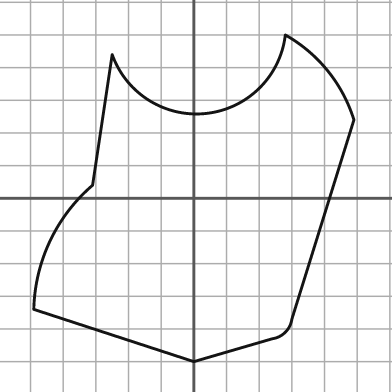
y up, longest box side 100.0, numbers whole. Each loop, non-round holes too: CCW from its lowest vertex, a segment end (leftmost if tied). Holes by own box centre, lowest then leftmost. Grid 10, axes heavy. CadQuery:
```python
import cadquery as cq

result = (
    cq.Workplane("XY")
    .moveTo(0.0, -50.0)
    .lineTo(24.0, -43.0)
    .threePointArc((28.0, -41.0), (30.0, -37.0))
    .lineTo(49.0, 24.0)
    .threePointArc((41.0, 39.0), (28.0, 50.0))
    .threePointArc((4.0, 26.0), (-25.0, 44.0))
    .lineTo(-31.0, 4.0)
    .threePointArc((-44.0, -13.0), (-49.0, -34.0))
    .close()
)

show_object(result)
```